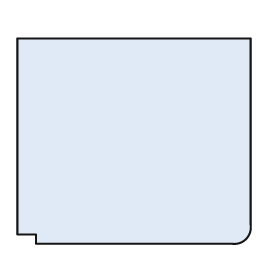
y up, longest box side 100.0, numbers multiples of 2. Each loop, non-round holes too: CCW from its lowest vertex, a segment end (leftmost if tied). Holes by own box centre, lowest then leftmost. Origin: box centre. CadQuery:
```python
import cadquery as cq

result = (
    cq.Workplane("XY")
    .moveTo(-42.0, -44.0)
    .lineTo(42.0, -44.0)
    .threePointArc((48.0, -42.0), (50.0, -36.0))
    .lineTo(50.0, 44.0)
    .lineTo(-50.0, 44.0)
    .lineTo(-50.0, -40.0)
    .lineTo(-42.0, -40.0)
    .close()
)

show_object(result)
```